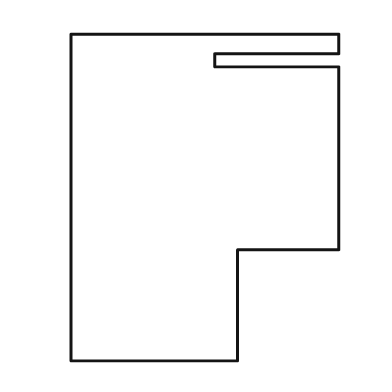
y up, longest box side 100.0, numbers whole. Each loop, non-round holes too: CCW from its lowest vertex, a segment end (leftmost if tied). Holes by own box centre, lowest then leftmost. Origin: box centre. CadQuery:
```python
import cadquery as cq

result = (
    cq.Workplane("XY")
    .moveTo(-41.0, -50.0)
    .lineTo(10.0, -50.0)
    .lineTo(10.0, -16.0)
    .lineTo(41.0, -16.0)
    .lineTo(41.0, 40.0)
    .lineTo(3.0, 40.0)
    .lineTo(3.0, 44.0)
    .lineTo(41.0, 44.0)
    .lineTo(41.0, 50.0)
    .lineTo(-41.0, 50.0)
    .close()
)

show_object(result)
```